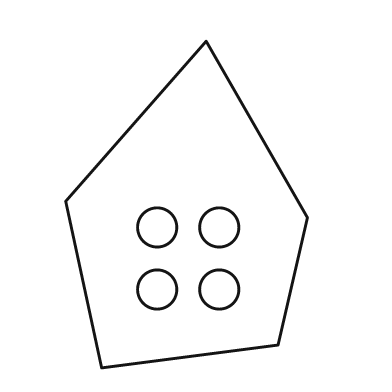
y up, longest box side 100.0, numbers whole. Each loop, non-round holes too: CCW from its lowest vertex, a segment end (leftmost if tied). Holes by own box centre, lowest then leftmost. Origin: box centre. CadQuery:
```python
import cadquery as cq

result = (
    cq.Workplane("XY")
    .moveTo(-26.0, -50.0)
    .lineTo(28.0, -43.0)
    .lineTo(37.0, -4.0)
    .lineTo(6.0, 50.0)
    .lineTo(-37.0, 1.0)
    .close()
    .moveTo(-9.0, -26.0)
    .circle(6.0)
    .moveTo(10.0, -26.0)
    .circle(6.0)
    .moveTo(-9.0, -7.0)
    .circle(6.0)
    .moveTo(10.0, -7.0)
    .circle(6.0)
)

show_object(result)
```